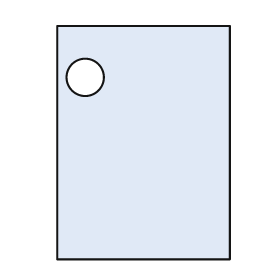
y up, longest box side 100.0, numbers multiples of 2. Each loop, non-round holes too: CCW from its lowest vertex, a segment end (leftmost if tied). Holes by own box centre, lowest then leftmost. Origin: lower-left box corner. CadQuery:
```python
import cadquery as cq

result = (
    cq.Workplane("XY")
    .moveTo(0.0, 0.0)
    .lineTo(74.0, 0.0)
    .lineTo(74.0, 100.0)
    .lineTo(0.0, 100.0)
    .close()
    .moveTo(12.0, 78.0)
    .circle(8.0)
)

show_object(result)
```